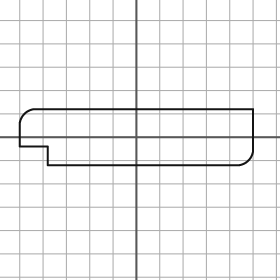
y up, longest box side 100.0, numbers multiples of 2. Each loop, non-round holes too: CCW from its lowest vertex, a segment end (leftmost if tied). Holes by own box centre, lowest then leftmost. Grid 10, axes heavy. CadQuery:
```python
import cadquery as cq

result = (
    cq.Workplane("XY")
    .moveTo(-38.0, -12.0)
    .lineTo(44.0, -12.0)
    .threePointArc((48.0, -10.0), (50.0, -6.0))
    .lineTo(50.0, 12.0)
    .lineTo(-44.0, 12.0)
    .threePointArc((-48.0, 10.0), (-50.0, 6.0))
    .lineTo(-50.0, -4.0)
    .lineTo(-38.0, -4.0)
    .close()
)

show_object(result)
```